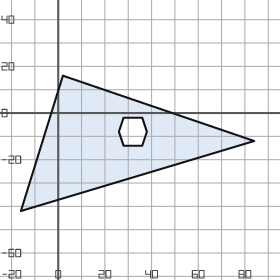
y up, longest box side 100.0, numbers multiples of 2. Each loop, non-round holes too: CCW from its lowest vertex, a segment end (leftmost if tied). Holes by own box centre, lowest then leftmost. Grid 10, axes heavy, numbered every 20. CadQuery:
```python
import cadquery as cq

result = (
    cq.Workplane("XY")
    .moveTo(-16.0, -42.0)
    .lineTo(84.0, -12.0)
    .lineTo(2.0, 16.0)
    .close()
    .moveTo(28.0, -14.0)
    .lineTo(36.0, -14.0)
    .lineTo(38.0, -8.0)
    .lineTo(36.0, -2.0)
    .lineTo(28.0, -2.0)
    .lineTo(26.0, -8.0)
    .close()
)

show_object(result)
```